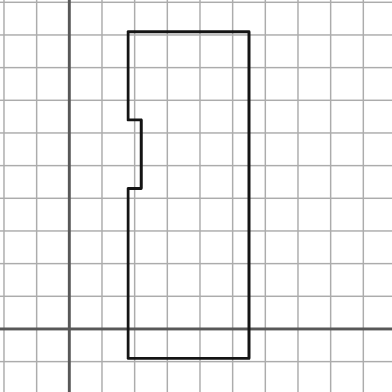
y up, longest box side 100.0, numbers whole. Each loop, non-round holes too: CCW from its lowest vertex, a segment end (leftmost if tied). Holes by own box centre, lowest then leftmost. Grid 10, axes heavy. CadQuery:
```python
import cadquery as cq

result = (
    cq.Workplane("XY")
    .moveTo(18.0, -9.0)
    .lineTo(55.0, -9.0)
    .lineTo(55.0, 91.0)
    .lineTo(18.0, 91.0)
    .lineTo(18.0, 64.0)
    .lineTo(22.0, 64.0)
    .lineTo(22.0, 43.0)
    .lineTo(18.0, 43.0)
    .close()
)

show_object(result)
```